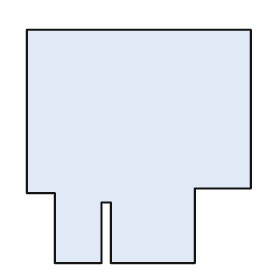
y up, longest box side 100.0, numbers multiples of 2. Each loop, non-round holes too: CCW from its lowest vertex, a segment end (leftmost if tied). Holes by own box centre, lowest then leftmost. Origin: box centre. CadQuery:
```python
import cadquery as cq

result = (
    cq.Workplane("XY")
    .moveTo(-36.0, -50.0)
    .lineTo(-16.0, -50.0)
    .lineTo(-16.0, -24.0)
    .lineTo(-12.0, -24.0)
    .lineTo(-12.0, -50.0)
    .lineTo(24.0, -50.0)
    .lineTo(24.0, -18.0)
    .lineTo(48.0, -18.0)
    .lineTo(48.0, 50.0)
    .lineTo(-48.0, 50.0)
    .lineTo(-48.0, -20.0)
    .lineTo(-36.0, -20.0)
    .close()
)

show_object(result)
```